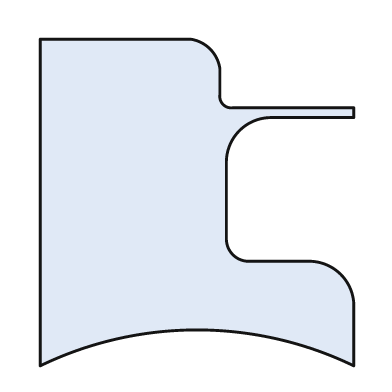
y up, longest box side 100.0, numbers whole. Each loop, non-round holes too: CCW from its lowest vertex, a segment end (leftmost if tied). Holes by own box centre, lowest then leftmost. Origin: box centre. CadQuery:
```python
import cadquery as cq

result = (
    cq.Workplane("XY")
    .moveTo(-48.0, -50.0)
    .threePointArc((0.0, -39.0), (48.0, -50.0))
    .lineTo(48.0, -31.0)
    .threePointArc((44.0, -22.0), (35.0, -18.0))
    .lineTo(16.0, -18.0)
    .threePointArc((11.0, -16.0), (9.0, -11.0))
    .lineTo(9.0, 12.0)
    .threePointArc((13.0, 22.0), (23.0, 26.0))
    .lineTo(48.0, 26.0)
    .lineTo(48.0, 29.0)
    .lineTo(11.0, 29.0)
    .threePointArc((8.0, 30.0), (7.0, 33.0))
    .lineTo(7.0, 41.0)
    .threePointArc((4.0, 47.0), (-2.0, 50.0))
    .lineTo(-48.0, 50.0)
    .close()
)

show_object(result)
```